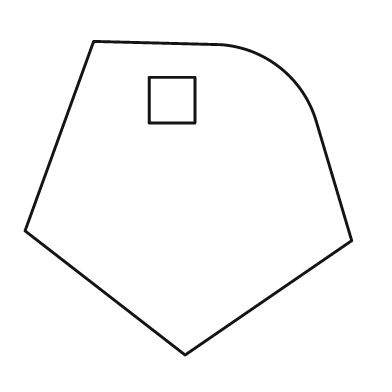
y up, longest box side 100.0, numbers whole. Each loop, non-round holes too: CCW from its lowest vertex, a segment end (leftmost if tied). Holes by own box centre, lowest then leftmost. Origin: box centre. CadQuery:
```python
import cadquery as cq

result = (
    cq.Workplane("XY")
    .moveTo(-1.0, -48.0)
    .lineTo(50.0, -13.0)
    .lineTo(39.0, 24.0)
    .threePointArc((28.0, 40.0), (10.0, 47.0))
    .lineTo(-29.0, 48.0)
    .lineTo(-50.0, -10.0)
    .close()
    .moveTo(-12.0, 23.0)
    .lineTo(2.0, 23.0)
    .lineTo(2.0, 37.0)
    .lineTo(-12.0, 37.0)
    .close()
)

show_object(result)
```